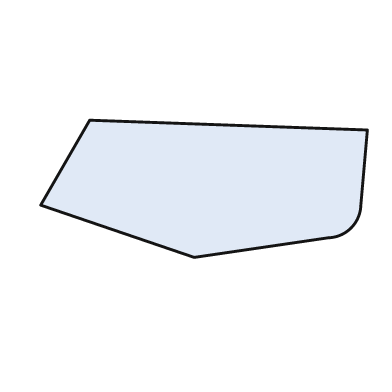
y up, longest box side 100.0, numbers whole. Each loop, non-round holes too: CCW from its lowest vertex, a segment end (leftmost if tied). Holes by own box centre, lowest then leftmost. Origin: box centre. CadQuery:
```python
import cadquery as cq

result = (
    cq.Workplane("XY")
    .moveTo(-3.0, -21.0)
    .lineTo(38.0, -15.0)
    .threePointArc((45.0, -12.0), (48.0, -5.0))
    .lineTo(50.0, 18.0)
    .lineTo(-35.0, 21.0)
    .lineTo(-50.0, -5.0)
    .close()
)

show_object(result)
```